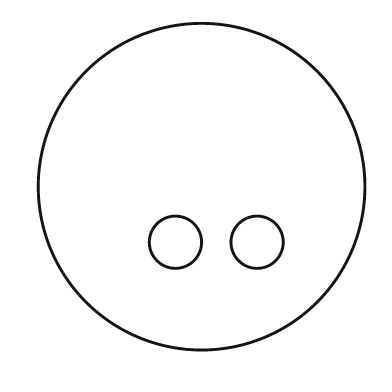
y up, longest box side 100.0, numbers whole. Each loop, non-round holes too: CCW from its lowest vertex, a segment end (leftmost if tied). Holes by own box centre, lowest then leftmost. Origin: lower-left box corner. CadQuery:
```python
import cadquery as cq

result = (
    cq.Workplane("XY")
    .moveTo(50.0, 50.0)
    .circle(50.0)
    .moveTo(42.0, 33.0)
    .circle(8.0)
    .moveTo(67.0, 33.0)
    .circle(8.0)
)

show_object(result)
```